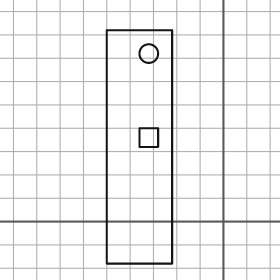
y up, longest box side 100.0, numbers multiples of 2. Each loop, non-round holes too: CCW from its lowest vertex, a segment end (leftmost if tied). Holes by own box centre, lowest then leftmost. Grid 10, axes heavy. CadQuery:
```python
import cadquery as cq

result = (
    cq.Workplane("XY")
    .moveTo(-50.0, -18.0)
    .lineTo(-22.0, -18.0)
    .lineTo(-22.0, 82.0)
    .lineTo(-50.0, 82.0)
    .close()
    .moveTo(-36.0, 32.0)
    .lineTo(-28.0, 32.0)
    .lineTo(-28.0, 40.0)
    .lineTo(-36.0, 40.0)
    .close()
    .moveTo(-32.0, 72.0)
    .circle(4.0)
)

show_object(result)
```